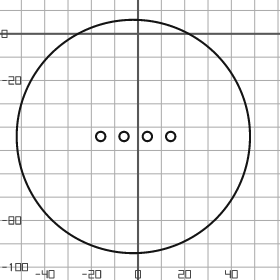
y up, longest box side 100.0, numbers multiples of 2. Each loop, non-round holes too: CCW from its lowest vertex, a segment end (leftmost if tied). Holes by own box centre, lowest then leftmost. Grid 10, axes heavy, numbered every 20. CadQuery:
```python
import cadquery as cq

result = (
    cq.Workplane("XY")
    .moveTo(-2.0, -44.0)
    .circle(50.0)
    .moveTo(-16.0, -44.0)
    .circle(2.0)
    .moveTo(-6.0, -44.0)
    .circle(2.0)
    .moveTo(4.0, -44.0)
    .circle(2.0)
    .moveTo(14.0, -44.0)
    .circle(2.0)
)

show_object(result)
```